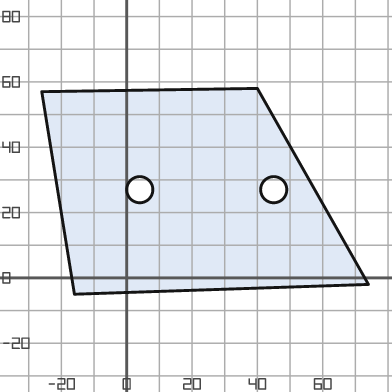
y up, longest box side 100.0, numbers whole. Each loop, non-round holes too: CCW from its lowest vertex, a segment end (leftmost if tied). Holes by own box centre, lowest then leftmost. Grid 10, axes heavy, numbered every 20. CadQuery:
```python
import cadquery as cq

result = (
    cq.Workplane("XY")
    .moveTo(-16.0, -5.0)
    .lineTo(74.0, -2.0)
    .lineTo(40.0, 58.0)
    .lineTo(-26.0, 57.0)
    .close()
    .moveTo(4.0, 27.0)
    .circle(4.0)
    .moveTo(45.0, 27.0)
    .circle(4.0)
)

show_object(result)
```